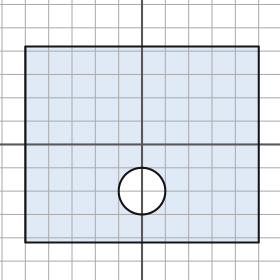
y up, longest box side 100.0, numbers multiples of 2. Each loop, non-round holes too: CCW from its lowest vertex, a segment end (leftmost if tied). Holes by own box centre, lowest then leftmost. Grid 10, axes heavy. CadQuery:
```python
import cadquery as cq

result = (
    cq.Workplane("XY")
    .moveTo(-50.0, -42.0)
    .lineTo(50.0, -42.0)
    .lineTo(50.0, 42.0)
    .lineTo(-50.0, 42.0)
    .close()
    .moveTo(0.0, -20.0)
    .circle(10.0)
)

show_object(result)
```